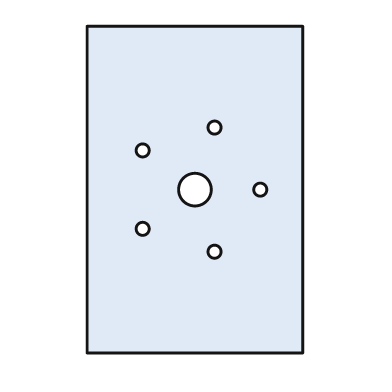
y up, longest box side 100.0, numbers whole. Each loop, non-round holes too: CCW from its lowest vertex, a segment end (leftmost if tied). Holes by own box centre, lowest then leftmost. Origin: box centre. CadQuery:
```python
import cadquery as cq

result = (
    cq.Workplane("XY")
    .moveTo(-33.0, -50.0)
    .lineTo(33.0, -50.0)
    .lineTo(33.0, 50.0)
    .lineTo(-33.0, 50.0)
    .close()
    .moveTo(6.0, -19.0)
    .circle(2.0)
    .moveTo(-16.0, -12.0)
    .circle(2.0)
    .moveTo(0.0, 0.0)
    .circle(5.0)
    .moveTo(20.0, 0.0)
    .circle(2.0)
    .moveTo(-16.0, 12.0)
    .circle(2.0)
    .moveTo(6.0, 19.0)
    .circle(2.0)
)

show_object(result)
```